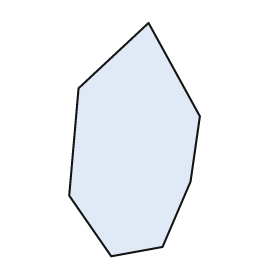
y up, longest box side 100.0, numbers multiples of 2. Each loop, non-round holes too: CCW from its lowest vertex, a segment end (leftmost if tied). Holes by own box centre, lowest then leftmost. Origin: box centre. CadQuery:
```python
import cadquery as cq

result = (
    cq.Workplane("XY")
    .moveTo(-10.0, -50.0)
    .lineTo(12.0, -46.0)
    .lineTo(24.0, -18.0)
    .lineTo(28.0, 10.0)
    .lineTo(6.0, 50.0)
    .lineTo(-24.0, 22.0)
    .lineTo(-28.0, -24.0)
    .close()
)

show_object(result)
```